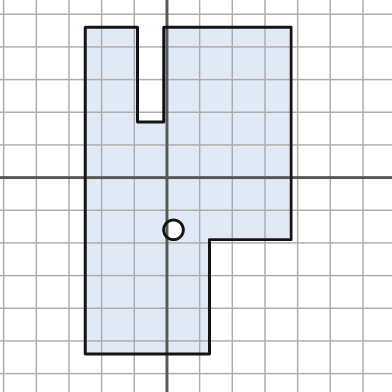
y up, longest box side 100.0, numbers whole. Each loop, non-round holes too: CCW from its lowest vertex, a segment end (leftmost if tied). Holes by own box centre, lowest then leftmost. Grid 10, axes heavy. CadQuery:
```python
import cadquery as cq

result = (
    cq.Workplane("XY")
    .moveTo(-25.0, -54.0)
    .lineTo(13.0, -54.0)
    .lineTo(13.0, -19.0)
    .lineTo(38.0, -19.0)
    .lineTo(38.0, 46.0)
    .lineTo(-1.0, 46.0)
    .lineTo(-1.0, 17.0)
    .lineTo(-9.0, 17.0)
    .lineTo(-9.0, 46.0)
    .lineTo(-25.0, 46.0)
    .close()
    .moveTo(2.0, -16.0)
    .circle(3.0)
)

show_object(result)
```